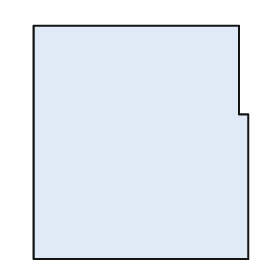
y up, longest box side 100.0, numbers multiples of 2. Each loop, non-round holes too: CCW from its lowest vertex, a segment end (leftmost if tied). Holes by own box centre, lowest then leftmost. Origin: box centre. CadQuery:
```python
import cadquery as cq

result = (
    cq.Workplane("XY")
    .moveTo(-46.0, -50.0)
    .lineTo(46.0, -50.0)
    .lineTo(46.0, 12.0)
    .lineTo(42.0, 12.0)
    .lineTo(42.0, 50.0)
    .lineTo(-46.0, 50.0)
    .close()
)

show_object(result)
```